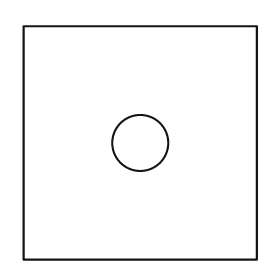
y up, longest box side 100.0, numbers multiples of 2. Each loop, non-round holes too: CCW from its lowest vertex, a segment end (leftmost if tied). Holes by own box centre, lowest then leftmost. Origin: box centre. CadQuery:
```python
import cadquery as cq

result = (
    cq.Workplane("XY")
    .moveTo(-50.0, -50.0)
    .lineTo(50.0, -50.0)
    .lineTo(50.0, 50.0)
    .lineTo(-50.0, 50.0)
    .close()
    .moveTo(0.0, 0.0)
    .circle(12.0)
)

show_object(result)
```